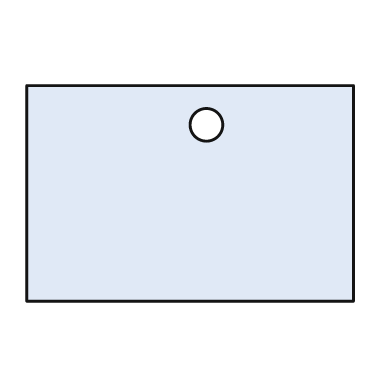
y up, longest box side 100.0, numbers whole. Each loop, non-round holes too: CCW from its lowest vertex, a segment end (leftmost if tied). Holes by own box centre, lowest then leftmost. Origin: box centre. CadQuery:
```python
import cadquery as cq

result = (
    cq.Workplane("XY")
    .moveTo(-50.0, -33.0)
    .lineTo(50.0, -33.0)
    .lineTo(50.0, 33.0)
    .lineTo(-50.0, 33.0)
    .close()
    .moveTo(5.0, 21.0)
    .circle(5.0)
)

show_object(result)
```